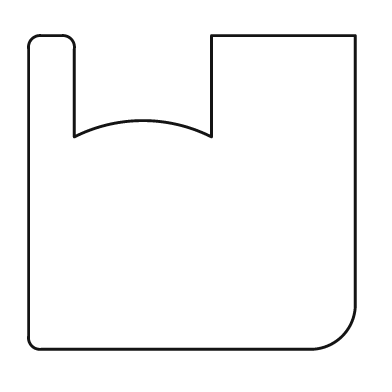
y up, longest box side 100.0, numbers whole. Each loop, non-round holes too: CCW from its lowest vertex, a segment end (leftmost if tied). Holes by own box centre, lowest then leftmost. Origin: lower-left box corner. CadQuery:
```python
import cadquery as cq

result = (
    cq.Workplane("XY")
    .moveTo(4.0, 0.0)
    .lineTo(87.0, 0.0)
    .threePointArc((96.0, 4.0), (100.0, 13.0))
    .lineTo(100.0, 96.0)
    .lineTo(56.0, 96.0)
    .lineTo(56.0, 65.0)
    .threePointArc((35.0, 70.0), (14.0, 65.0))
    .lineTo(14.0, 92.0)
    .threePointArc((13.0, 95.0), (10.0, 96.0))
    .lineTo(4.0, 96.0)
    .threePointArc((1.0, 95.0), (0.0, 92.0))
    .lineTo(0.0, 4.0)
    .threePointArc((1.0, 1.0), (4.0, 0.0))
    .close()
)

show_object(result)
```